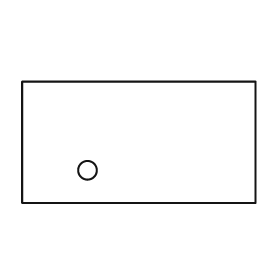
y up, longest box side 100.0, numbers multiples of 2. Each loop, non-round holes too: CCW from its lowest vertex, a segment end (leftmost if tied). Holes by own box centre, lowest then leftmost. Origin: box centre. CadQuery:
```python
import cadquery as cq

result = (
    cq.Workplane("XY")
    .moveTo(-50.0, -26.0)
    .lineTo(50.0, -26.0)
    .lineTo(50.0, 26.0)
    .lineTo(-50.0, 26.0)
    .close()
    .moveTo(-22.0, -12.0)
    .circle(4.0)
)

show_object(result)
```